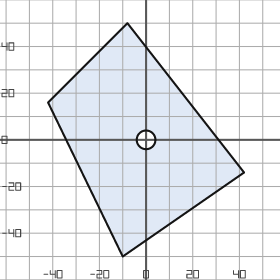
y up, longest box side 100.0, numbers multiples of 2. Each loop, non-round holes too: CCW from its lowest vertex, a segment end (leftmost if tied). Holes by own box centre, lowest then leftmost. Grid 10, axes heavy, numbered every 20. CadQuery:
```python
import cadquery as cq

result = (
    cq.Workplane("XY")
    .moveTo(-10.0, -50.0)
    .lineTo(42.0, -14.0)
    .lineTo(-8.0, 50.0)
    .lineTo(-42.0, 16.0)
    .close()
    .moveTo(0.0, 0.0)
    .circle(4.0)
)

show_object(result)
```